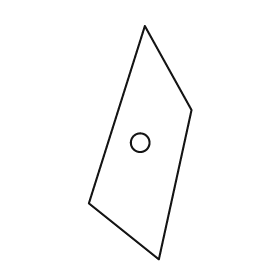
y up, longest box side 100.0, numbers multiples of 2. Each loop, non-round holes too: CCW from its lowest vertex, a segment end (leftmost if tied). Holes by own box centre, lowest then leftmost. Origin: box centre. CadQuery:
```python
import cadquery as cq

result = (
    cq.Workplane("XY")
    .moveTo(8.0, -50.0)
    .lineTo(22.0, 14.0)
    .lineTo(2.0, 50.0)
    .lineTo(-22.0, -26.0)
    .close()
    .moveTo(0.0, 0.0)
    .circle(4.0)
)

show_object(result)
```